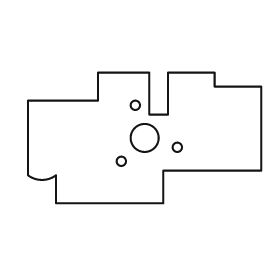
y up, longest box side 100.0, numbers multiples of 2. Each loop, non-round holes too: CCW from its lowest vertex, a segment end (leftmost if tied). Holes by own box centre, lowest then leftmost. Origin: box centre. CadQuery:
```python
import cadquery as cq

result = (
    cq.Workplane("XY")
    .moveTo(-38.0, -28.0)
    .lineTo(8.0, -28.0)
    .lineTo(8.0, -14.0)
    .lineTo(50.0, -14.0)
    .lineTo(50.0, 22.0)
    .lineTo(30.0, 22.0)
    .lineTo(30.0, 28.0)
    .lineTo(10.0, 28.0)
    .lineTo(10.0, 10.0)
    .lineTo(2.0, 10.0)
    .lineTo(2.0, 28.0)
    .lineTo(-20.0, 28.0)
    .lineTo(-20.0, 16.0)
    .lineTo(-50.0, 16.0)
    .lineTo(-50.0, -16.0)
    .threePointArc((-44.0, -18.0), (-38.0, -16.0))
    .close()
    .moveTo(-10.0, -10.0)
    .circle(2.0)
    .moveTo(14.0, -4.0)
    .circle(2.0)
    .moveTo(0.0, 0.0)
    .circle(6.0)
    .moveTo(-4.0, 14.0)
    .circle(2.0)
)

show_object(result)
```